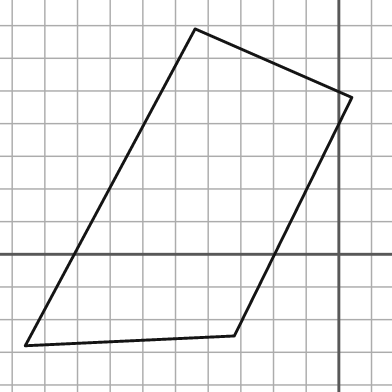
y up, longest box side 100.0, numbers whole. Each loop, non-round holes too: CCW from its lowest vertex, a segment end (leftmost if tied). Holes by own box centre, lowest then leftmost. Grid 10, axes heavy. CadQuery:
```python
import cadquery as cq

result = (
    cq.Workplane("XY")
    .moveTo(-96.0, -28.0)
    .lineTo(-32.0, -25.0)
    .lineTo(4.0, 48.0)
    .lineTo(-44.0, 69.0)
    .close()
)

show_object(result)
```